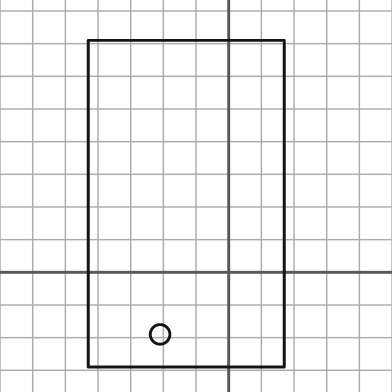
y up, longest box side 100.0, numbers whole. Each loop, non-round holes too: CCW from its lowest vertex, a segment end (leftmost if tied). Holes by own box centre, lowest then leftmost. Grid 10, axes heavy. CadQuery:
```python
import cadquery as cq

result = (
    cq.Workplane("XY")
    .moveTo(-43.0, -29.0)
    .lineTo(17.0, -29.0)
    .lineTo(17.0, 71.0)
    .lineTo(-43.0, 71.0)
    .close()
    .moveTo(-21.0, -19.0)
    .circle(3.0)
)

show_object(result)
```